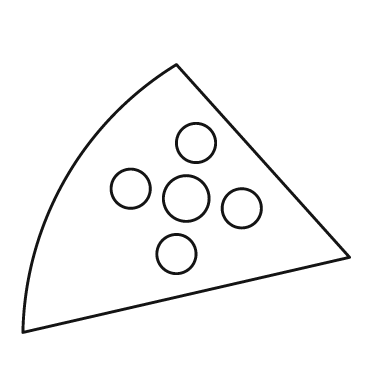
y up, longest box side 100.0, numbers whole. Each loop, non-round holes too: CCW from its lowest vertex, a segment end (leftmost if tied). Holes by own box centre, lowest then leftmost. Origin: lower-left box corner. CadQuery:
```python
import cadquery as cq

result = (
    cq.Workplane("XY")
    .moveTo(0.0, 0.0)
    .lineTo(100.0, 23.0)
    .lineTo(47.0, 82.0)
    .threePointArc((13.0, 47.0), (0.0, 0.0))
    .close()
    .moveTo(47.0, 24.0)
    .circle(6.0)
    .moveTo(67.0, 38.0)
    .circle(6.0)
    .moveTo(50.0, 41.0)
    .circle(7.0)
    .moveTo(33.0, 44.0)
    .circle(6.0)
    .moveTo(53.0, 58.0)
    .circle(6.0)
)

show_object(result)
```